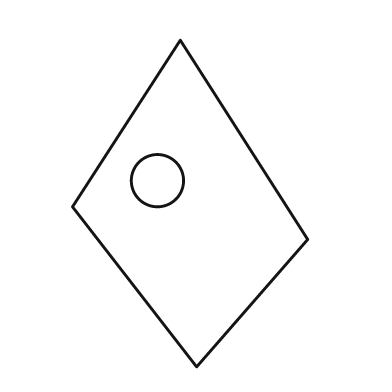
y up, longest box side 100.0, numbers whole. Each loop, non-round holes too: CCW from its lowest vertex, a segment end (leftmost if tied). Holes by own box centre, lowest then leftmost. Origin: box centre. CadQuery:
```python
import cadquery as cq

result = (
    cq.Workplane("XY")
    .moveTo(2.0, -50.0)
    .lineTo(36.0, -11.0)
    .lineTo(-3.0, 50.0)
    .lineTo(-36.0, -1.0)
    .close()
    .moveTo(-10.0, 7.0)
    .circle(8.0)
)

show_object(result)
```